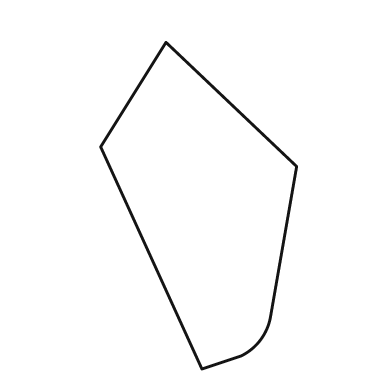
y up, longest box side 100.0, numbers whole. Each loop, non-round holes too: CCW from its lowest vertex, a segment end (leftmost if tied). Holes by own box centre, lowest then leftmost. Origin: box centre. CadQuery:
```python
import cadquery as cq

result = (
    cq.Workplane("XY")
    .moveTo(1.0, -50.0)
    .lineTo(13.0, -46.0)
    .threePointArc((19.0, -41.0), (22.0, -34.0))
    .lineTo(30.0, 12.0)
    .lineTo(-10.0, 50.0)
    .lineTo(-30.0, 18.0)
    .close()
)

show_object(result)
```